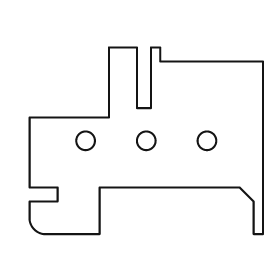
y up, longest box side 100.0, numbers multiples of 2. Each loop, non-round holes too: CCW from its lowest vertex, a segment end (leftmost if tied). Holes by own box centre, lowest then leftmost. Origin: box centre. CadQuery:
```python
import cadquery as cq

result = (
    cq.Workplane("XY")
    .moveTo(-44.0, -40.0)
    .lineTo(-20.0, -40.0)
    .lineTo(-20.0, -20.0)
    .lineTo(40.0, -20.0)
    .lineTo(46.0, -26.0)
    .lineTo(46.0, -40.0)
    .lineTo(50.0, -40.0)
    .lineTo(50.0, 34.0)
    .lineTo(6.0, 34.0)
    .lineTo(6.0, 40.0)
    .lineTo(2.0, 40.0)
    .lineTo(2.0, 14.0)
    .lineTo(-4.0, 14.0)
    .lineTo(-4.0, 40.0)
    .lineTo(-16.0, 40.0)
    .lineTo(-16.0, 10.0)
    .lineTo(-50.0, 10.0)
    .lineTo(-50.0, -20.0)
    .lineTo(-38.0, -20.0)
    .lineTo(-38.0, -26.0)
    .lineTo(-50.0, -26.0)
    .lineTo(-50.0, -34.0)
    .threePointArc((-48.0, -38.0), (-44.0, -40.0))
    .close()
    .moveTo(-26.0, 0.0)
    .circle(4.0)
    .moveTo(0.0, 0.0)
    .circle(4.0)
    .moveTo(26.0, 0.0)
    .circle(4.0)
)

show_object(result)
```